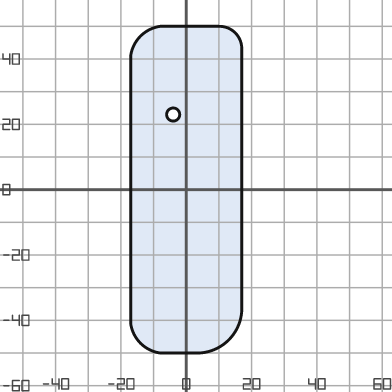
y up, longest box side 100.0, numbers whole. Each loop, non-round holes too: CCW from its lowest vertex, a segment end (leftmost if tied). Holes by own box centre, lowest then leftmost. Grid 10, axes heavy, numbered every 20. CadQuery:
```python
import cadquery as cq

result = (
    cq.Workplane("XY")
    .moveTo(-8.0, -50.0)
    .lineTo(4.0, -50.0)
    .threePointArc((13.0, -46.0), (17.0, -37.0))
    .lineTo(17.0, 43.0)
    .threePointArc((15.0, 48.0), (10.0, 50.0))
    .lineTo(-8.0, 50.0)
    .threePointArc((-14.0, 47.0), (-17.0, 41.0))
    .lineTo(-17.0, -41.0)
    .threePointArc((-14.0, -47.0), (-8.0, -50.0))
    .close()
    .moveTo(-4.0, 23.0)
    .circle(2.0)
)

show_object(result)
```